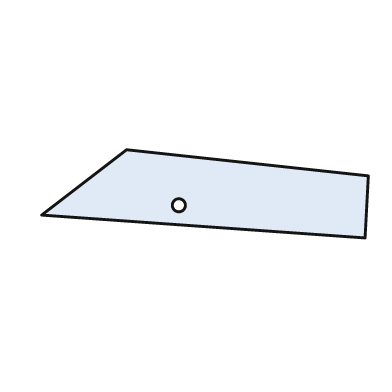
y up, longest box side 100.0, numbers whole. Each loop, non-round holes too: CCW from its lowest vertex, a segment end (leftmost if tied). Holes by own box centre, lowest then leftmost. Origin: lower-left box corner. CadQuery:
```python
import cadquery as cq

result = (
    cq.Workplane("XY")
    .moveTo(99.0, 0.0)
    .lineTo(100.0, 19.0)
    .lineTo(26.0, 27.0)
    .lineTo(0.0, 7.0)
    .close()
    .moveTo(42.0, 10.0)
    .circle(2.0)
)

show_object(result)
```